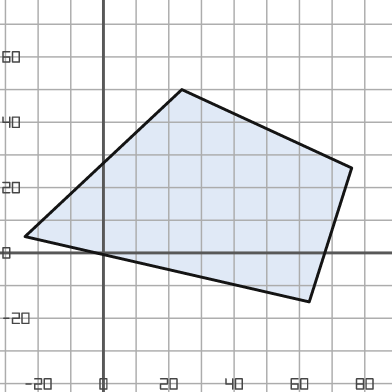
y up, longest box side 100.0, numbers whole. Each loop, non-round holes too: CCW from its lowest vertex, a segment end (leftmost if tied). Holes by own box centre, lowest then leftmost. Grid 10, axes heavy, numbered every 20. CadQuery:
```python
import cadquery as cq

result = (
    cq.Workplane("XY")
    .moveTo(63.0, -15.0)
    .lineTo(76.0, 26.0)
    .lineTo(24.0, 50.0)
    .lineTo(-24.0, 5.0)
    .close()
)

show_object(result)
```